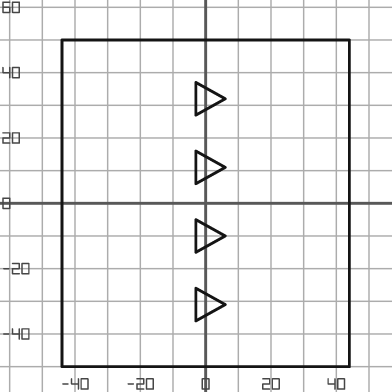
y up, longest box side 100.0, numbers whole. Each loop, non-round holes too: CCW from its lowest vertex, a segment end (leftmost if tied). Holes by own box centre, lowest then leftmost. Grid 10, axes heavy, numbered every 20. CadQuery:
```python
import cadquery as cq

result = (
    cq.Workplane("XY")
    .moveTo(-44.0, -50.0)
    .lineTo(44.0, -50.0)
    .lineTo(44.0, 50.0)
    .lineTo(-44.0, 50.0)
    .close()
    .moveTo(-3.0, -36.0)
    .lineTo(6.0, -31.0)
    .lineTo(-3.0, -26.0)
    .close()
    .moveTo(-3.0, -15.0)
    .lineTo(6.0, -10.0)
    .lineTo(-3.0, -5.0)
    .close()
    .moveTo(-3.0, 6.0)
    .lineTo(6.0, 11.0)
    .lineTo(-3.0, 16.0)
    .close()
    .moveTo(-3.0, 27.0)
    .lineTo(6.0, 32.0)
    .lineTo(-3.0, 37.0)
    .close()
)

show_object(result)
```